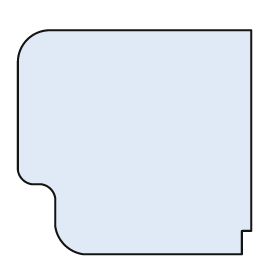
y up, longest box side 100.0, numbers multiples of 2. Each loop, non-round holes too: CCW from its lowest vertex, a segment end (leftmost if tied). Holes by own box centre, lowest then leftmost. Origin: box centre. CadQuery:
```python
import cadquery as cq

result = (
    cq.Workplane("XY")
    .moveTo(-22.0, -48.0)
    .lineTo(46.0, -48.0)
    .lineTo(46.0, -38.0)
    .lineTo(50.0, -38.0)
    .lineTo(50.0, 48.0)
    .lineTo(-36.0, 48.0)
    .threePointArc((-46.0, 44.0), (-50.0, 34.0))
    .lineTo(-50.0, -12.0)
    .threePointArc((-48.0, -16.0), (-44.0, -18.0))
    .lineTo(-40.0, -18.0)
    .threePointArc((-36.0, -20.0), (-34.0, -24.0))
    .lineTo(-34.0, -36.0)
    .threePointArc((-30.0, -44.0), (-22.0, -48.0))
    .close()
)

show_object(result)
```